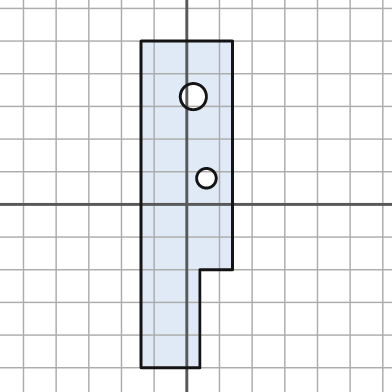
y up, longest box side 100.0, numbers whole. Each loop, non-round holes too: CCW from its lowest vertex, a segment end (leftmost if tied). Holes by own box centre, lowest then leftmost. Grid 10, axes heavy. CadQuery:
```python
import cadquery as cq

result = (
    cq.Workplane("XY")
    .moveTo(-14.0, -50.0)
    .lineTo(4.0, -50.0)
    .lineTo(4.0, -20.0)
    .lineTo(14.0, -20.0)
    .lineTo(14.0, 50.0)
    .lineTo(-14.0, 50.0)
    .close()
    .moveTo(6.0, 8.0)
    .circle(3.0)
    .moveTo(2.0, 33.0)
    .circle(4.0)
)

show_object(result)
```